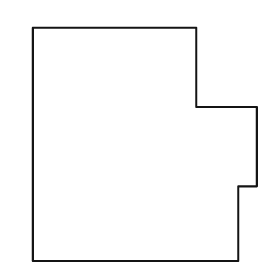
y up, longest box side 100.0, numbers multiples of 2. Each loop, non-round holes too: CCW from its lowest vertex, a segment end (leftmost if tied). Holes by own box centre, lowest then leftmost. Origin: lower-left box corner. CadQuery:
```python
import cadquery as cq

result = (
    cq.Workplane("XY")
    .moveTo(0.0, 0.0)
    .lineTo(88.0, 0.0)
    .lineTo(88.0, 32.0)
    .lineTo(96.0, 32.0)
    .lineTo(96.0, 66.0)
    .lineTo(70.0, 66.0)
    .lineTo(70.0, 100.0)
    .lineTo(0.0, 100.0)
    .close()
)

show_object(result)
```